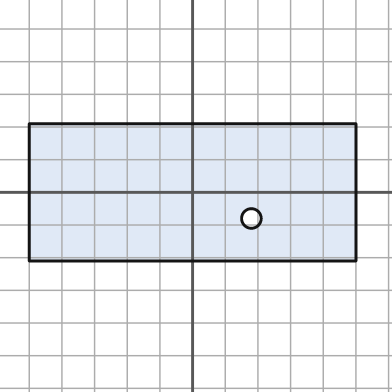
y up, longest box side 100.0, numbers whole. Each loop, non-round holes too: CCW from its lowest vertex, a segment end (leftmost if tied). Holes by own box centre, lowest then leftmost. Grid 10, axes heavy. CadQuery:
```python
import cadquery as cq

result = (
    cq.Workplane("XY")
    .moveTo(-50.0, -21.0)
    .lineTo(50.0, -21.0)
    .lineTo(50.0, 21.0)
    .lineTo(-50.0, 21.0)
    .close()
    .moveTo(18.0, -8.0)
    .circle(3.0)
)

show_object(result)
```